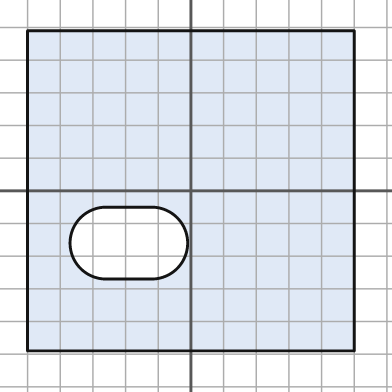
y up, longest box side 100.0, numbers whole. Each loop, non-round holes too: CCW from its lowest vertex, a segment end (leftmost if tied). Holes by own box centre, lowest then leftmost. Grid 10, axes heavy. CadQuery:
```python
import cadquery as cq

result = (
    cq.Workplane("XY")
    .moveTo(-50.0, -49.0)
    .lineTo(50.0, -49.0)
    .lineTo(50.0, 49.0)
    .lineTo(-50.0, 49.0)
    .close()
    .moveTo(-26.0, -27.0)
    .lineTo(-12.0, -27.0)
    .threePointArc((-1.0, -16.0), (-12.0, -5.0))
    .lineTo(-26.0, -5.0)
    .threePointArc((-37.0, -16.0), (-26.0, -27.0))
    .close()
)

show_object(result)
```